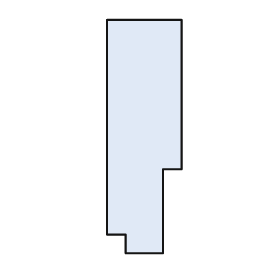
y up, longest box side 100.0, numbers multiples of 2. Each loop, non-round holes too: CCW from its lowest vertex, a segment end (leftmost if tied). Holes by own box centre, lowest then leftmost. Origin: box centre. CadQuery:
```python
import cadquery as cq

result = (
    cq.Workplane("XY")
    .moveTo(-8.0, -50.0)
    .lineTo(8.0, -50.0)
    .lineTo(8.0, -14.0)
    .lineTo(16.0, -14.0)
    .lineTo(16.0, 50.0)
    .lineTo(-16.0, 50.0)
    .lineTo(-16.0, -42.0)
    .lineTo(-8.0, -42.0)
    .close()
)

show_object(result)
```